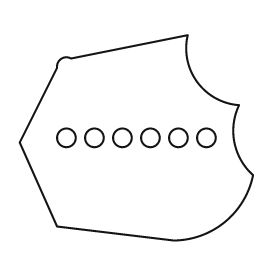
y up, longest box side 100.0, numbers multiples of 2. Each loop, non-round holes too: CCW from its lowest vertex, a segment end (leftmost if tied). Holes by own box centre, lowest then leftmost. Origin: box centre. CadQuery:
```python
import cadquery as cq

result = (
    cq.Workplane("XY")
    .moveTo(16.0, -44.0)
    .threePointArc((38.0, -36.0), (50.0, -16.0))
    .threePointArc((42.0, -2.0), (44.0, 14.0))
    .threePointArc((26.0, 24.0), (22.0, 44.0))
    .lineTo(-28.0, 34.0)
    .threePointArc((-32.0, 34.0), (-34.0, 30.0))
    .lineTo(-50.0, -2.0)
    .lineTo(-34.0, -38.0)
    .close()
    .moveTo(-30.0, 0.0)
    .circle(4.0)
    .moveTo(-18.0, 0.0)
    .circle(4.0)
    .moveTo(-6.0, 0.0)
    .circle(4.0)
    .moveTo(6.0, 0.0)
    .circle(4.0)
    .moveTo(18.0, 0.0)
    .circle(4.0)
    .moveTo(30.0, 0.0)
    .circle(4.0)
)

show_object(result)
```